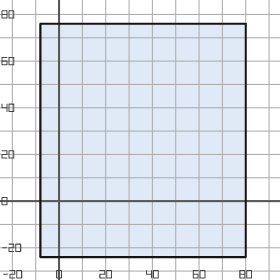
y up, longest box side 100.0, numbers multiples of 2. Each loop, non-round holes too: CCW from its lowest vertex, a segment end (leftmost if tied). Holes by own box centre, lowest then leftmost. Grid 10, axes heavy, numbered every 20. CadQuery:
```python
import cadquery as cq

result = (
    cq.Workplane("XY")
    .moveTo(-8.0, -24.0)
    .lineTo(80.0, -24.0)
    .lineTo(80.0, 76.0)
    .lineTo(-8.0, 76.0)
    .close()
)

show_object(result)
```